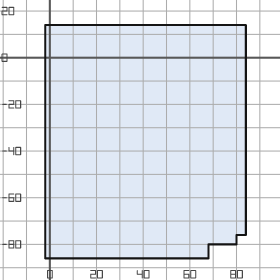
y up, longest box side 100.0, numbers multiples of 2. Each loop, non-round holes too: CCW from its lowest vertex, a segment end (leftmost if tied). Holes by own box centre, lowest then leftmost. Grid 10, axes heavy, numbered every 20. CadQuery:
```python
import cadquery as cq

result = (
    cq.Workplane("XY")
    .moveTo(-2.0, -86.0)
    .lineTo(68.0, -86.0)
    .lineTo(68.0, -80.0)
    .lineTo(80.0, -80.0)
    .lineTo(80.0, -76.0)
    .lineTo(84.0, -76.0)
    .lineTo(84.0, 14.0)
    .lineTo(-2.0, 14.0)
    .close()
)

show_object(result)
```